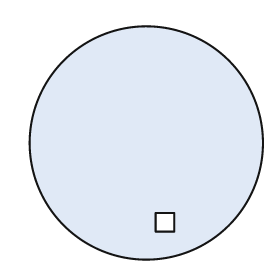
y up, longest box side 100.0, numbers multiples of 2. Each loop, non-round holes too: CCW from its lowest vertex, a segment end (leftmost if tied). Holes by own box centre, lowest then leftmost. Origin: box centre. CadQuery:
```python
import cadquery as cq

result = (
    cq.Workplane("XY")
    .moveTo(0.0, 0.0)
    .circle(50.0)
    .moveTo(4.0, -38.0)
    .lineTo(12.0, -38.0)
    .lineTo(12.0, -30.0)
    .lineTo(4.0, -30.0)
    .close()
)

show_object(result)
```